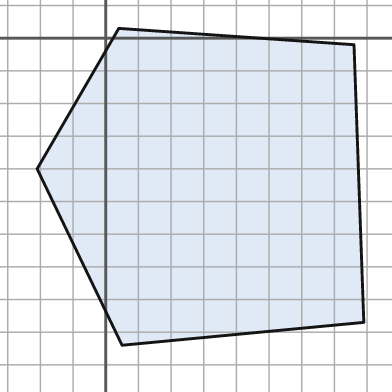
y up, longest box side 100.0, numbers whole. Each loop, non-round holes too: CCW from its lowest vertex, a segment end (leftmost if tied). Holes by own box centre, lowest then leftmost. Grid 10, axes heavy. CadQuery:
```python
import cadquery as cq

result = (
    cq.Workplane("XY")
    .moveTo(5.0, -94.0)
    .lineTo(79.0, -87.0)
    .lineTo(76.0, -2.0)
    .lineTo(4.0, 3.0)
    .lineTo(-21.0, -40.0)
    .close()
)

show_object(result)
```